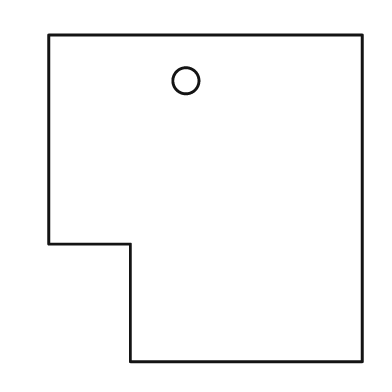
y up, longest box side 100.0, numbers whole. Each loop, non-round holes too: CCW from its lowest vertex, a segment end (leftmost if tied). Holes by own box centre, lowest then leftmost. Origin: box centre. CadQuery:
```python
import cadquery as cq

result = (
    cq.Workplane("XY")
    .moveTo(-23.0, -50.0)
    .lineTo(48.0, -50.0)
    .lineTo(48.0, 50.0)
    .lineTo(-48.0, 50.0)
    .lineTo(-48.0, -14.0)
    .lineTo(-23.0, -14.0)
    .close()
    .moveTo(-6.0, 36.0)
    .circle(4.0)
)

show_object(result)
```